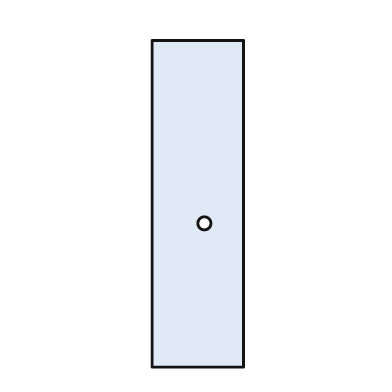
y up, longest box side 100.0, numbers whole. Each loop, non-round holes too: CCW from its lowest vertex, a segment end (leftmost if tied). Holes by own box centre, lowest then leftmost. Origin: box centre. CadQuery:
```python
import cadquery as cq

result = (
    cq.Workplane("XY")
    .moveTo(-14.0, -50.0)
    .lineTo(14.0, -50.0)
    .lineTo(14.0, 50.0)
    .lineTo(-14.0, 50.0)
    .close()
    .moveTo(2.0, -6.0)
    .circle(2.0)
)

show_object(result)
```